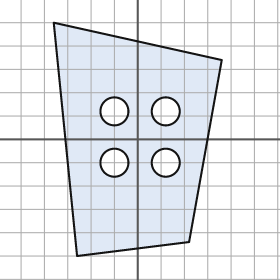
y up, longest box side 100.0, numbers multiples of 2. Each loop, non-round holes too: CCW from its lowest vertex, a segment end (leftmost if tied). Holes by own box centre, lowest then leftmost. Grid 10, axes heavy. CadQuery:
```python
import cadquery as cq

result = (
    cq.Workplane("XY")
    .moveTo(-26.0, -50.0)
    .lineTo(22.0, -44.0)
    .lineTo(36.0, 34.0)
    .lineTo(-36.0, 50.0)
    .close()
    .moveTo(-10.0, -10.0)
    .circle(6.0)
    .moveTo(12.0, -10.0)
    .circle(6.0)
    .moveTo(-10.0, 12.0)
    .circle(6.0)
    .moveTo(12.0, 12.0)
    .circle(6.0)
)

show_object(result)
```